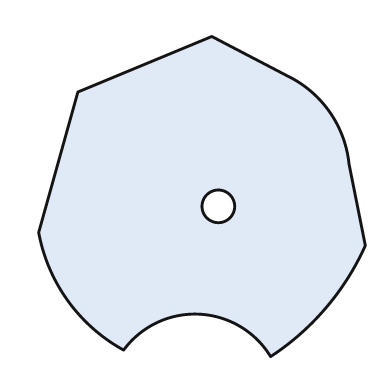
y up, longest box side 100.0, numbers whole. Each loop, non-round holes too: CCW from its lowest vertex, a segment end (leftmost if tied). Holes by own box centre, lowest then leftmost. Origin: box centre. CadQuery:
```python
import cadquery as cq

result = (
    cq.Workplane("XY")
    .moveTo(21.0, -49.0)
    .threePointArc((38.0, -34.0), (50.0, -15.0))
    .lineTo(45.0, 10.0)
    .threePointArc((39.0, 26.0), (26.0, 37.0))
    .lineTo(3.0, 49.0)
    .lineTo(-38.0, 32.0)
    .lineTo(-50.0, -11.0)
    .threePointArc((-41.0, -32.0), (-24.0, -47.0))
    .threePointArc((-1.0, -36.0), (21.0, -49.0))
    .close()
    .moveTo(5.0, -3.0)
    .circle(5.0)
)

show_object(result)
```